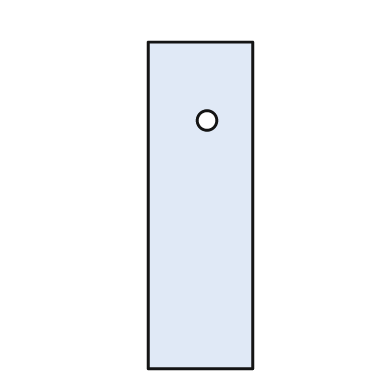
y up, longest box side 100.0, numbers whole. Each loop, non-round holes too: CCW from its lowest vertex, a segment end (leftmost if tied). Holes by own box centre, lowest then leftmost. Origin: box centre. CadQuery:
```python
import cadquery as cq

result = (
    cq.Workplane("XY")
    .moveTo(-16.0, -50.0)
    .lineTo(16.0, -50.0)
    .lineTo(16.0, 50.0)
    .lineTo(-16.0, 50.0)
    .close()
    .moveTo(2.0, 26.0)
    .circle(3.0)
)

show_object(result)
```